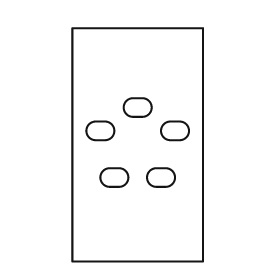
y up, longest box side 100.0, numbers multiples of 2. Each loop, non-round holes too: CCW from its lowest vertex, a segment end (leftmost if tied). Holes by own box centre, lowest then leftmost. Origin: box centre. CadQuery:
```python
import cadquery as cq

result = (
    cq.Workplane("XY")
    .moveTo(-28.0, -50.0)
    .lineTo(28.0, -50.0)
    .lineTo(28.0, 50.0)
    .lineTo(-28.0, 50.0)
    .close()
    .moveTo(-12.0, -18.0)
    .lineTo(-8.0, -18.0)
    .threePointArc((-4.0, -14.0), (-8.0, -10.0))
    .lineTo(-12.0, -10.0)
    .threePointArc((-16.0, -14.0), (-12.0, -18.0))
    .close()
    .moveTo(8.0, -18.0)
    .lineTo(12.0, -18.0)
    .threePointArc((16.0, -14.0), (12.0, -10.0))
    .lineTo(8.0, -10.0)
    .threePointArc((4.0, -14.0), (8.0, -18.0))
    .close()
    .moveTo(-18.0, 2.0)
    .lineTo(-14.0, 2.0)
    .threePointArc((-10.0, 6.0), (-14.0, 10.0))
    .lineTo(-18.0, 10.0)
    .threePointArc((-22.0, 6.0), (-18.0, 2.0))
    .close()
    .moveTo(14.0, 2.0)
    .lineTo(18.0, 2.0)
    .threePointArc((22.0, 6.0), (18.0, 10.0))
    .lineTo(14.0, 10.0)
    .threePointArc((10.0, 6.0), (14.0, 2.0))
    .close()
    .moveTo(-2.0, 12.0)
    .lineTo(2.0, 12.0)
    .threePointArc((6.0, 16.0), (2.0, 20.0))
    .lineTo(-2.0, 20.0)
    .threePointArc((-6.0, 16.0), (-2.0, 12.0))
    .close()
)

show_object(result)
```